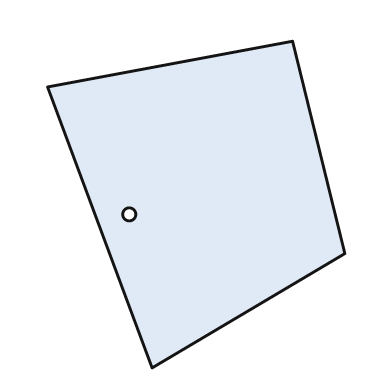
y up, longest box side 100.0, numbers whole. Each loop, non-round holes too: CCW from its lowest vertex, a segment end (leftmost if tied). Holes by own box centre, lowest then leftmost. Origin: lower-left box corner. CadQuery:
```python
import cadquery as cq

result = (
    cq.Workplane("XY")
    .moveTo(32.0, 0.0)
    .lineTo(91.0, 35.0)
    .lineTo(75.0, 100.0)
    .lineTo(0.0, 86.0)
    .close()
    .moveTo(25.0, 47.0)
    .circle(2.0)
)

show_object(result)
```